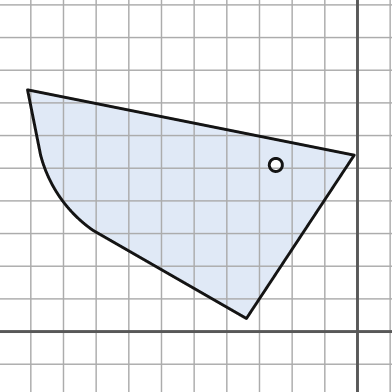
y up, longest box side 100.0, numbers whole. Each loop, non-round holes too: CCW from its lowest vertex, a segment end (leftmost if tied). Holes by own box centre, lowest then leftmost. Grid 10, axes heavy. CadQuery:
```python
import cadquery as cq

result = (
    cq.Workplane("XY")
    .moveTo(-34.0, 4.0)
    .lineTo(-1.0, 54.0)
    .lineTo(-101.0, 74.0)
    .lineTo(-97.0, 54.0)
    .threePointArc((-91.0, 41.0), (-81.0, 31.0))
    .close()
    .moveTo(-25.0, 51.0)
    .circle(2.0)
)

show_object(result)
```